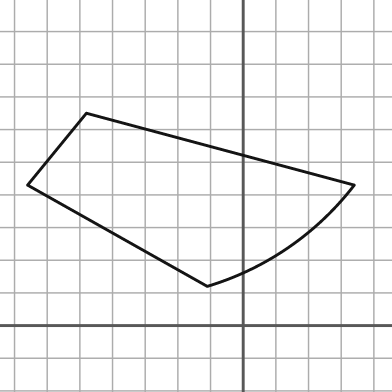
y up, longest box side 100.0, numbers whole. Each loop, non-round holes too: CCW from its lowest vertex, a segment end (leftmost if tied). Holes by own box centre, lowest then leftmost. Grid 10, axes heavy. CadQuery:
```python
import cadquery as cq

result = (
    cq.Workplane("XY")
    .moveTo(-11.0, 12.0)
    .threePointArc((14.0, 24.0), (34.0, 43.0))
    .lineTo(-48.0, 65.0)
    .lineTo(-66.0, 43.0)
    .close()
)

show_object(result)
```